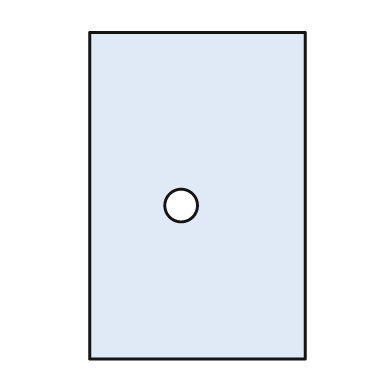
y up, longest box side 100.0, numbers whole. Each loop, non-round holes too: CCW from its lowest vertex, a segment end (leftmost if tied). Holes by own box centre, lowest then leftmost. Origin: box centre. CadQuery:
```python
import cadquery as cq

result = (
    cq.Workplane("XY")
    .moveTo(-33.0, -50.0)
    .lineTo(33.0, -50.0)
    .lineTo(33.0, 50.0)
    .lineTo(-33.0, 50.0)
    .close()
    .moveTo(-5.0, -3.0)
    .circle(5.0)
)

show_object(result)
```